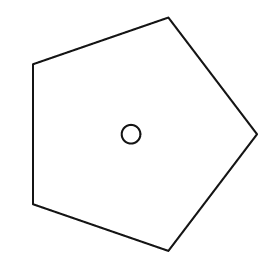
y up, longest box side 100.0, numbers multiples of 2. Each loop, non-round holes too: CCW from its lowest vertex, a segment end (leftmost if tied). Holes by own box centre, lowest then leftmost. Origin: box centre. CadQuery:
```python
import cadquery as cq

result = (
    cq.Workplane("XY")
    .moveTo(10.0, -50.0)
    .lineTo(48.0, 0.0)
    .lineTo(10.0, 50.0)
    .lineTo(-48.0, 30.0)
    .lineTo(-48.0, -30.0)
    .close()
    .moveTo(-6.0, 0.0)
    .circle(4.0)
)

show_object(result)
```